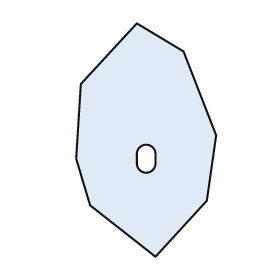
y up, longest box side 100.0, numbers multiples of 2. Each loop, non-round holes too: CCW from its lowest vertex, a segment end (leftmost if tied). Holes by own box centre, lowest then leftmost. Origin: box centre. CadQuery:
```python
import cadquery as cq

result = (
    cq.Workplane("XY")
    .moveTo(4.0, -50.0)
    .lineTo(26.0, -26.0)
    .lineTo(30.0, 2.0)
    .lineTo(16.0, 38.0)
    .lineTo(-4.0, 50.0)
    .lineTo(-28.0, 24.0)
    .lineTo(-30.0, -8.0)
    .lineTo(-24.0, -28.0)
    .close()
    .moveTo(-4.0, -10.0)
    .threePointArc((0.0, -14.0), (4.0, -10.0))
    .lineTo(4.0, -6.0)
    .threePointArc((0.0, -2.0), (-4.0, -6.0))
    .close()
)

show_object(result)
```